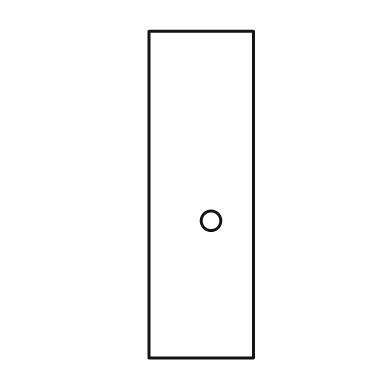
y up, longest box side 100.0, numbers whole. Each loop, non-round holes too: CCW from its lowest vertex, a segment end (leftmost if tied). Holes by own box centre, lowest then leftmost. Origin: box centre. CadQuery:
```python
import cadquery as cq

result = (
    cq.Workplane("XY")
    .moveTo(-16.0, -50.0)
    .lineTo(16.0, -50.0)
    .lineTo(16.0, 50.0)
    .lineTo(-16.0, 50.0)
    .close()
    .moveTo(3.0, -8.0)
    .circle(3.0)
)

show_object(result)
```